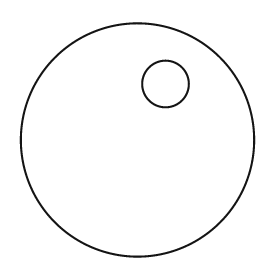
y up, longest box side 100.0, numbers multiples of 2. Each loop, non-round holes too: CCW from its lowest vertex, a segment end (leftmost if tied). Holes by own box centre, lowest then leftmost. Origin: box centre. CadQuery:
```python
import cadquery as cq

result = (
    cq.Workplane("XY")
    .moveTo(0.0, 0.0)
    .circle(50.0)
    .moveTo(12.0, 24.0)
    .circle(10.0)
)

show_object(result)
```